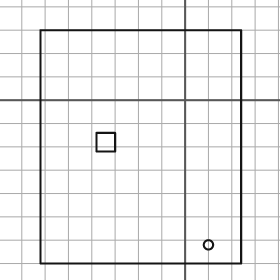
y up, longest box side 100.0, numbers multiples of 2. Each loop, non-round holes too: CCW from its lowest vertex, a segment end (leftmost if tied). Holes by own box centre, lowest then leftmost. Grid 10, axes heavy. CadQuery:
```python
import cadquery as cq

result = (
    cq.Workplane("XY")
    .moveTo(-62.0, -70.0)
    .lineTo(24.0, -70.0)
    .lineTo(24.0, 30.0)
    .lineTo(-62.0, 30.0)
    .close()
    .moveTo(10.0, -62.0)
    .circle(2.0)
    .moveTo(-38.0, -22.0)
    .lineTo(-30.0, -22.0)
    .lineTo(-30.0, -14.0)
    .lineTo(-38.0, -14.0)
    .close()
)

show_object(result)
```